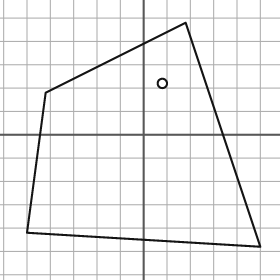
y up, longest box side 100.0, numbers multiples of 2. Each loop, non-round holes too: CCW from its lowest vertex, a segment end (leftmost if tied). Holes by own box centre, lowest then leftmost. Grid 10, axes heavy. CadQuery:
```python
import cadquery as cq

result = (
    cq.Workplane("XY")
    .moveTo(50.0, -48.0)
    .lineTo(18.0, 48.0)
    .lineTo(-42.0, 18.0)
    .lineTo(-50.0, -42.0)
    .close()
    .moveTo(8.0, 22.0)
    .circle(2.0)
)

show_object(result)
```